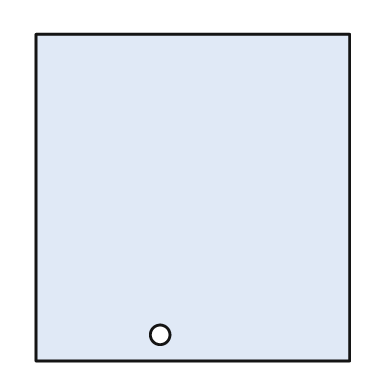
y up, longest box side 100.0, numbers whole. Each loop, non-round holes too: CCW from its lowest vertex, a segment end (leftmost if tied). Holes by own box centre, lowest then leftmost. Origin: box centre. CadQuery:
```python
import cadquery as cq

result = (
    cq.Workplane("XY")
    .moveTo(-48.0, -50.0)
    .lineTo(48.0, -50.0)
    .lineTo(48.0, 50.0)
    .lineTo(-48.0, 50.0)
    .close()
    .moveTo(-10.0, -42.0)
    .circle(3.0)
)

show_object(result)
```